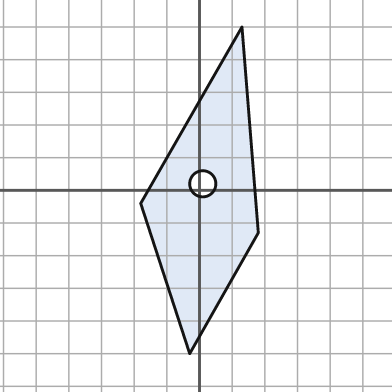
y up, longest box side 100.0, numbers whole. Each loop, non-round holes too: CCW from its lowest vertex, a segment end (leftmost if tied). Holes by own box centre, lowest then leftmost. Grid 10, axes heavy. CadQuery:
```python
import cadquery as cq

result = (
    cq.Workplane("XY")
    .moveTo(-3.0, -50.0)
    .lineTo(18.0, -13.0)
    .lineTo(13.0, 50.0)
    .lineTo(-18.0, -4.0)
    .close()
    .moveTo(1.0, 2.0)
    .circle(4.0)
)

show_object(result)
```